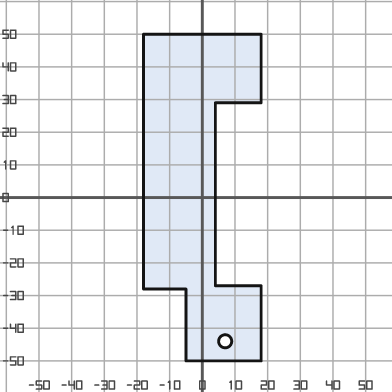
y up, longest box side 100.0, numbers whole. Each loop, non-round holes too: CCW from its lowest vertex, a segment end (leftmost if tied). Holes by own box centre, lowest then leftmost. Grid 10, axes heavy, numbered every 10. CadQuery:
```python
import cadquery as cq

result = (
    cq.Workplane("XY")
    .moveTo(-5.0, -50.0)
    .lineTo(18.0, -50.0)
    .lineTo(18.0, -27.0)
    .lineTo(4.0, -27.0)
    .lineTo(4.0, 29.0)
    .lineTo(18.0, 29.0)
    .lineTo(18.0, 50.0)
    .lineTo(-18.0, 50.0)
    .lineTo(-18.0, -28.0)
    .lineTo(-5.0, -28.0)
    .close()
    .moveTo(7.0, -44.0)
    .circle(2.0)
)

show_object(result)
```